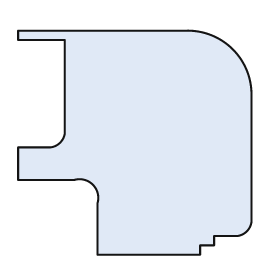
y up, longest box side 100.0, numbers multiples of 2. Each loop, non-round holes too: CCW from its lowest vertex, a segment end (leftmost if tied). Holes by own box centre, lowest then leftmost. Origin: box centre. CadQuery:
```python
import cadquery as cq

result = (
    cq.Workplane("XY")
    .moveTo(-16.0, -48.0)
    .lineTo(28.0, -48.0)
    .lineTo(28.0, -44.0)
    .lineTo(34.0, -44.0)
    .lineTo(34.0, -40.0)
    .lineTo(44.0, -40.0)
    .threePointArc((48.0, -38.0), (50.0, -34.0))
    .lineTo(50.0, 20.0)
    .threePointArc((42.0, 40.0), (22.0, 48.0))
    .lineTo(-50.0, 48.0)
    .lineTo(-50.0, 44.0)
    .lineTo(-30.0, 44.0)
    .lineTo(-30.0, 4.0)
    .threePointArc((-32.0, 0.0), (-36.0, -2.0))
    .lineTo(-50.0, -2.0)
    .lineTo(-50.0, -16.0)
    .lineTo(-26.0, -16.0)
    .threePointArc((-18.0, -18.0), (-16.0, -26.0))
    .close()
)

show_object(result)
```